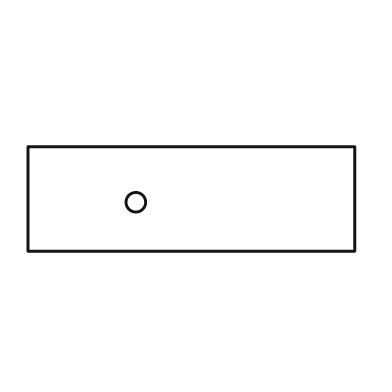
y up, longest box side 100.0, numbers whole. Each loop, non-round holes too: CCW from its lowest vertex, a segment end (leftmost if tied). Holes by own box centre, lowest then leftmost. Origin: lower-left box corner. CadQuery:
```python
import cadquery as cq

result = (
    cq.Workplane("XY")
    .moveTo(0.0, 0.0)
    .lineTo(100.0, 0.0)
    .lineTo(100.0, 32.0)
    .lineTo(0.0, 32.0)
    .close()
    .moveTo(33.0, 15.0)
    .circle(3.0)
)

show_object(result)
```